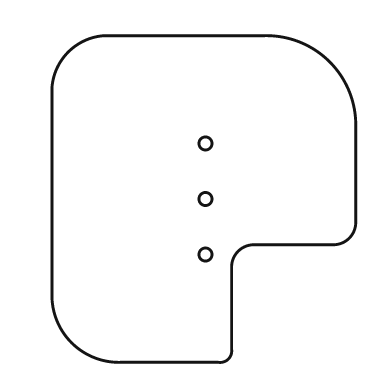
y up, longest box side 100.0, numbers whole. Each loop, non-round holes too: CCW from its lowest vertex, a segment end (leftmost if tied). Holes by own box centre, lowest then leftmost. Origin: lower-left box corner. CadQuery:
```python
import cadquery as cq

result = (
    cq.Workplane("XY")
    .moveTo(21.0, 0.0)
    .lineTo(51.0, 0.0)
    .threePointArc((54.0, 1.0), (55.0, 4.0))
    .lineTo(55.0, 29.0)
    .threePointArc((57.0, 34.0), (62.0, 36.0))
    .lineTo(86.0, 36.0)
    .threePointArc((91.0, 38.0), (93.0, 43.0))
    .lineTo(93.0, 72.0)
    .threePointArc((85.0, 92.0), (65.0, 100.0))
    .lineTo(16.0, 100.0)
    .threePointArc((5.0, 95.0), (0.0, 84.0))
    .lineTo(0.0, 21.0)
    .threePointArc((6.0, 6.0), (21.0, 0.0))
    .close()
    .moveTo(47.0, 33.0)
    .circle(2.0)
    .moveTo(47.0, 50.0)
    .circle(2.0)
    .moveTo(47.0, 67.0)
    .circle(2.0)
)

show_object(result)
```